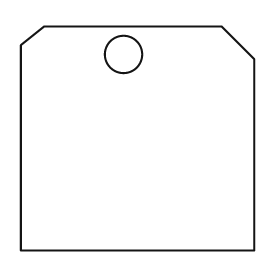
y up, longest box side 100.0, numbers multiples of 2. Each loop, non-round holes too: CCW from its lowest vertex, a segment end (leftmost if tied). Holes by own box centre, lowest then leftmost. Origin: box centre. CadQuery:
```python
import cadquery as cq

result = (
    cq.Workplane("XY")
    .moveTo(-50.0, -48.0)
    .lineTo(50.0, -48.0)
    .lineTo(50.0, 34.0)
    .lineTo(36.0, 48.0)
    .lineTo(-40.0, 48.0)
    .lineTo(-50.0, 40.0)
    .close()
    .moveTo(-6.0, 36.0)
    .circle(8.0)
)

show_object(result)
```